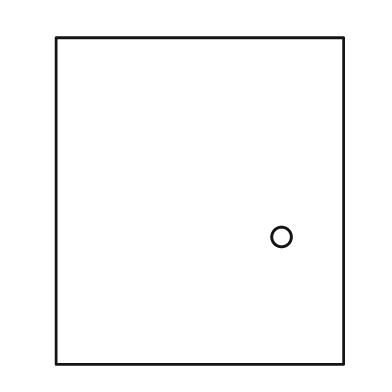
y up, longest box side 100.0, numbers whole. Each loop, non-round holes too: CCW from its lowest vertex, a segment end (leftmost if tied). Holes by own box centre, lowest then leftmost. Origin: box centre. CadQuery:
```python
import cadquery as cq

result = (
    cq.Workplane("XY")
    .moveTo(-44.0, -50.0)
    .lineTo(44.0, -50.0)
    .lineTo(44.0, 50.0)
    .lineTo(-44.0, 50.0)
    .close()
    .moveTo(25.0, -11.0)
    .circle(3.0)
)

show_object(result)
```